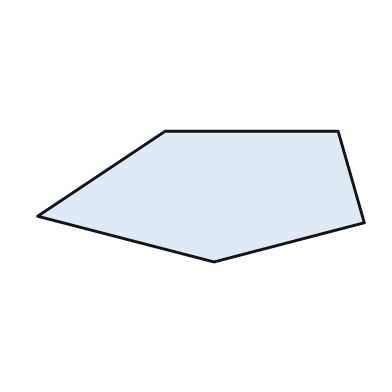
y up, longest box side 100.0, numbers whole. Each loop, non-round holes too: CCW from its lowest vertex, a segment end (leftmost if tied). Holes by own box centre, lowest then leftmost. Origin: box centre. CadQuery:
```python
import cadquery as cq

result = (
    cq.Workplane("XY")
    .moveTo(4.0, -20.0)
    .lineTo(50.0, -8.0)
    .lineTo(42.0, 20.0)
    .lineTo(-11.0, 20.0)
    .lineTo(-50.0, -6.0)
    .close()
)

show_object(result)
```